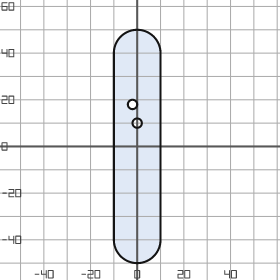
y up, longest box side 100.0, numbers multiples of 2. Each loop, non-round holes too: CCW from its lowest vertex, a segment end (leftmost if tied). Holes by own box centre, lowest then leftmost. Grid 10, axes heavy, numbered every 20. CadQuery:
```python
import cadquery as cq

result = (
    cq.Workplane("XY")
    .moveTo(-10.0, -40.0)
    .threePointArc((0.0, -50.0), (10.0, -40.0))
    .lineTo(10.0, 40.0)
    .threePointArc((0.0, 50.0), (-10.0, 40.0))
    .close()
    .moveTo(0.0, 10.0)
    .circle(2.0)
    .moveTo(-2.0, 18.0)
    .circle(2.0)
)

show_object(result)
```